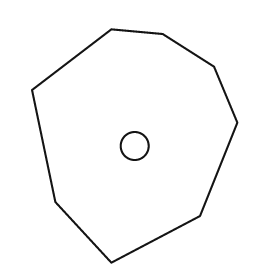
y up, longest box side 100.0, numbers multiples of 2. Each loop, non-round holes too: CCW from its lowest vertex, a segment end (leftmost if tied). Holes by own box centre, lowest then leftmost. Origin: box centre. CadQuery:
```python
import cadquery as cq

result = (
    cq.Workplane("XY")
    .moveTo(-10.0, -50.0)
    .lineTo(28.0, -30.0)
    .lineTo(44.0, 10.0)
    .lineTo(34.0, 34.0)
    .lineTo(12.0, 48.0)
    .lineTo(-10.0, 50.0)
    .lineTo(-44.0, 24.0)
    .lineTo(-34.0, -24.0)
    .close()
    .moveTo(0.0, 0.0)
    .circle(6.0)
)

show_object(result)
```